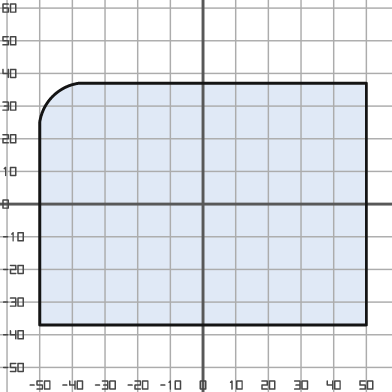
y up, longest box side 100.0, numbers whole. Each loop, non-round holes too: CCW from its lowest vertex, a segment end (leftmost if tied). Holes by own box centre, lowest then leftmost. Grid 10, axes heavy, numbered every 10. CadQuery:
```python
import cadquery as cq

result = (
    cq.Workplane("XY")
    .moveTo(-50.0, -37.0)
    .lineTo(50.0, -37.0)
    .lineTo(50.0, 37.0)
    .lineTo(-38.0, 37.0)
    .threePointArc((-46.0, 33.0), (-50.0, 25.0))
    .close()
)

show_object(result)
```